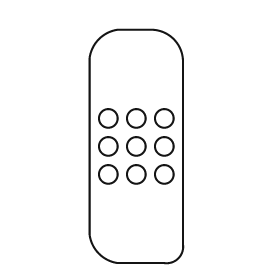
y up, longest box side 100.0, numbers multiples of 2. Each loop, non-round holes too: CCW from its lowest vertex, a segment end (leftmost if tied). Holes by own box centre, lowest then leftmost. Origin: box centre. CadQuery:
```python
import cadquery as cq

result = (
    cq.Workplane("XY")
    .moveTo(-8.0, -50.0)
    .lineTo(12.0, -50.0)
    .threePointArc((18.0, -48.0), (20.0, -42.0))
    .lineTo(20.0, 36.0)
    .threePointArc((16.0, 46.0), (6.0, 50.0))
    .lineTo(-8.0, 50.0)
    .threePointArc((-16.0, 46.0), (-20.0, 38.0))
    .lineTo(-20.0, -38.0)
    .threePointArc((-16.0, -46.0), (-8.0, -50.0))
    .close()
    .moveTo(-12.0, -12.0)
    .circle(4.0)
    .moveTo(0.0, -12.0)
    .circle(4.0)
    .moveTo(12.0, -12.0)
    .circle(4.0)
    .moveTo(-12.0, 0.0)
    .circle(4.0)
    .moveTo(0.0, 0.0)
    .circle(4.0)
    .moveTo(12.0, 0.0)
    .circle(4.0)
    .moveTo(-12.0, 12.0)
    .circle(4.0)
    .moveTo(0.0, 12.0)
    .circle(4.0)
    .moveTo(12.0, 12.0)
    .circle(4.0)
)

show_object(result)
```